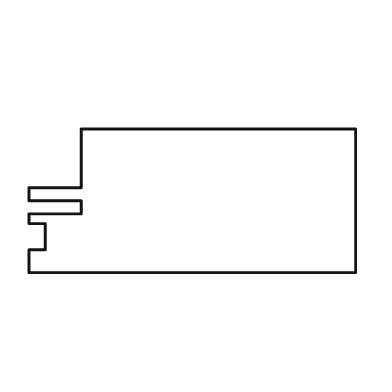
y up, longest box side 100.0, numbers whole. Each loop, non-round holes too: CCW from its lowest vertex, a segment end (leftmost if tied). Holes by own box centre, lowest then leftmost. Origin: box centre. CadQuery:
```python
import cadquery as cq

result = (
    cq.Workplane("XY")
    .moveTo(-50.0, -22.0)
    .lineTo(50.0, -22.0)
    .lineTo(50.0, 22.0)
    .lineTo(-34.0, 22.0)
    .lineTo(-34.0, 4.0)
    .lineTo(-50.0, 4.0)
    .lineTo(-50.0, 0.0)
    .lineTo(-34.0, 0.0)
    .lineTo(-34.0, -4.0)
    .lineTo(-50.0, -4.0)
    .lineTo(-50.0, -7.0)
    .lineTo(-45.0, -7.0)
    .lineTo(-45.0, -15.0)
    .lineTo(-50.0, -15.0)
    .close()
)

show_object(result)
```